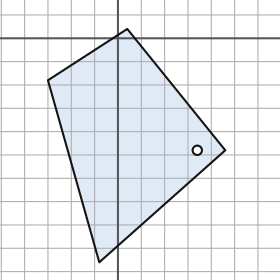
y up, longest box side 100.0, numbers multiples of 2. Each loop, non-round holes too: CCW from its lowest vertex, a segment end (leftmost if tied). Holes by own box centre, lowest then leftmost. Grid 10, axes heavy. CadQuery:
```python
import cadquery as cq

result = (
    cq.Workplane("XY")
    .moveTo(-8.0, -96.0)
    .lineTo(46.0, -48.0)
    .lineTo(4.0, 4.0)
    .lineTo(-30.0, -18.0)
    .close()
    .moveTo(34.0, -48.0)
    .circle(2.0)
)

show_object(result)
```